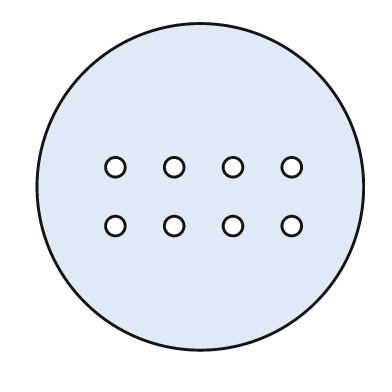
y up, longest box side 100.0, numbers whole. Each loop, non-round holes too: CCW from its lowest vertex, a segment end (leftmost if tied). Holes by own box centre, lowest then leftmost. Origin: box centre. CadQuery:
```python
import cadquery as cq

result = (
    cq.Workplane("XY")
    .moveTo(0.0, 0.0)
    .circle(50.0)
    .moveTo(-26.0, -12.0)
    .circle(3.0)
    .moveTo(-8.0, -12.0)
    .circle(3.0)
    .moveTo(10.0, -12.0)
    .circle(3.0)
    .moveTo(28.0, -12.0)
    .circle(3.0)
    .moveTo(-26.0, 6.0)
    .circle(3.0)
    .moveTo(-8.0, 6.0)
    .circle(3.0)
    .moveTo(10.0, 6.0)
    .circle(3.0)
    .moveTo(28.0, 6.0)
    .circle(3.0)
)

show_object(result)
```